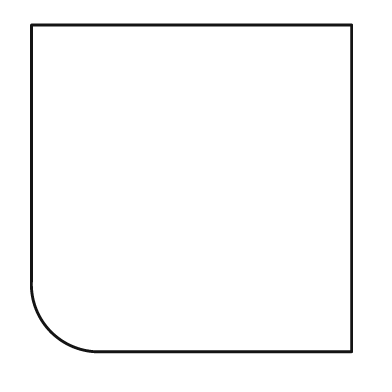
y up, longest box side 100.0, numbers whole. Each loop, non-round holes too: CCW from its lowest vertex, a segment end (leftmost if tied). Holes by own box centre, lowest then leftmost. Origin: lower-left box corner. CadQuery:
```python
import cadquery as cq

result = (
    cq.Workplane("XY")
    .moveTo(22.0, 0.0)
    .lineTo(98.0, 0.0)
    .lineTo(98.0, 100.0)
    .lineTo(0.0, 100.0)
    .lineTo(0.0, 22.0)
    .threePointArc((6.0, 6.0), (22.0, 0.0))
    .close()
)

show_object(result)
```